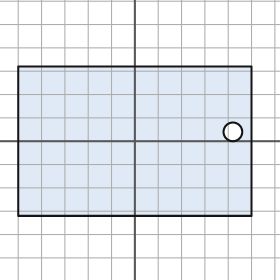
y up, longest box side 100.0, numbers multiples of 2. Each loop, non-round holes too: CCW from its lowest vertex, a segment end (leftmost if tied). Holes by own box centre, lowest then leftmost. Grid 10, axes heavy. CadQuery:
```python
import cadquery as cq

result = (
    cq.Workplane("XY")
    .moveTo(-50.0, -32.0)
    .lineTo(50.0, -32.0)
    .lineTo(50.0, 32.0)
    .lineTo(-50.0, 32.0)
    .close()
    .moveTo(42.0, 4.0)
    .circle(4.0)
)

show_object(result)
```